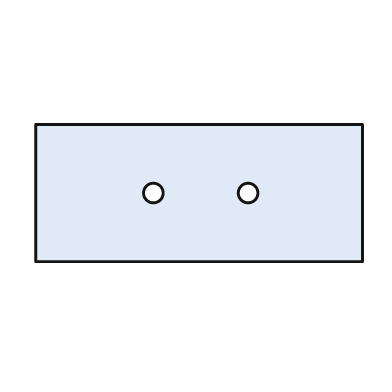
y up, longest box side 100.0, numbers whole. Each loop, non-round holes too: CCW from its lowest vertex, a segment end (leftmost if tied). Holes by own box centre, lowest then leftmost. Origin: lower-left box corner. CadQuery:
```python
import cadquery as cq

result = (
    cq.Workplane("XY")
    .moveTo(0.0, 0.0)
    .lineTo(100.0, 0.0)
    .lineTo(100.0, 42.0)
    .lineTo(0.0, 42.0)
    .close()
    .moveTo(36.0, 21.0)
    .circle(3.0)
    .moveTo(65.0, 21.0)
    .circle(3.0)
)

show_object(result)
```